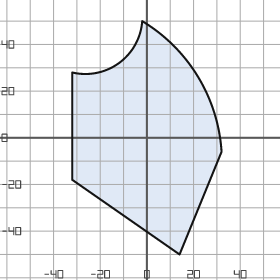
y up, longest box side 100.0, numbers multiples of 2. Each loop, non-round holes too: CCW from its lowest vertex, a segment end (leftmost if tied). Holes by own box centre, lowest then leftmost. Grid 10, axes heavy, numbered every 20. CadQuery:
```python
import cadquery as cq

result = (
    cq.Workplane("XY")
    .moveTo(14.0, -50.0)
    .lineTo(32.0, -6.0)
    .threePointArc((22.0, 26.0), (-2.0, 50.0))
    .threePointArc((-12.0, 32.0), (-32.0, 28.0))
    .lineTo(-32.0, -18.0)
    .close()
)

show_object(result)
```